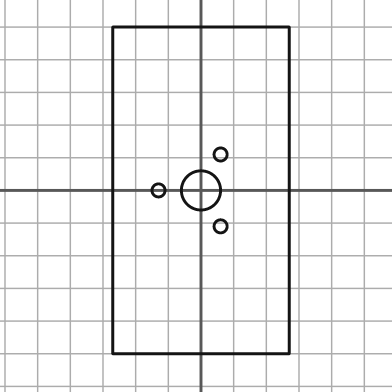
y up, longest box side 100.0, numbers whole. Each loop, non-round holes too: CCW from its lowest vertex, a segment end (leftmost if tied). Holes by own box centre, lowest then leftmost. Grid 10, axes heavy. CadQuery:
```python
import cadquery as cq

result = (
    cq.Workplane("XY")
    .moveTo(-27.0, -50.0)
    .lineTo(27.0, -50.0)
    .lineTo(27.0, 50.0)
    .lineTo(-27.0, 50.0)
    .close()
    .moveTo(6.0, -11.0)
    .circle(2.0)
    .moveTo(-13.0, 0.0)
    .circle(2.0)
    .moveTo(0.0, 0.0)
    .circle(6.0)
    .moveTo(6.0, 11.0)
    .circle(2.0)
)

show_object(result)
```